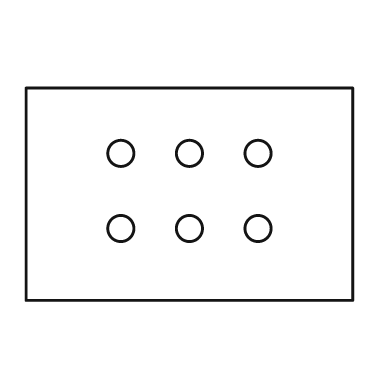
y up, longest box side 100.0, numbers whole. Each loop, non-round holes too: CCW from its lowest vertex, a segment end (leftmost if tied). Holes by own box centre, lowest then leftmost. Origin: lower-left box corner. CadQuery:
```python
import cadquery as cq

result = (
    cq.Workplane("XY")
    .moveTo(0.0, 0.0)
    .lineTo(100.0, 0.0)
    .lineTo(100.0, 65.0)
    .lineTo(0.0, 65.0)
    .close()
    .moveTo(29.0, 22.0)
    .circle(4.0)
    .moveTo(50.0, 22.0)
    .circle(4.0)
    .moveTo(71.0, 22.0)
    .circle(4.0)
    .moveTo(29.0, 45.0)
    .circle(4.0)
    .moveTo(50.0, 45.0)
    .circle(4.0)
    .moveTo(71.0, 45.0)
    .circle(4.0)
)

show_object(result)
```